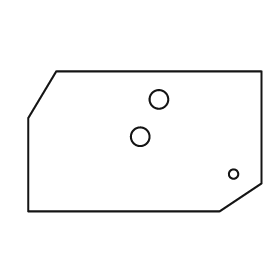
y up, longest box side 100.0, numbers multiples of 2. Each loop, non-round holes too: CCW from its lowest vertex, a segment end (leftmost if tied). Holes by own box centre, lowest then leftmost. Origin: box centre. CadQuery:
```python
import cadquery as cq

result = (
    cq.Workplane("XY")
    .moveTo(-50.0, -30.0)
    .lineTo(32.0, -30.0)
    .lineTo(50.0, -18.0)
    .lineTo(50.0, 30.0)
    .lineTo(-38.0, 30.0)
    .lineTo(-50.0, 10.0)
    .close()
    .moveTo(38.0, -14.0)
    .circle(2.0)
    .moveTo(-2.0, 2.0)
    .circle(4.0)
    .moveTo(6.0, 18.0)
    .circle(4.0)
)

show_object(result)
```